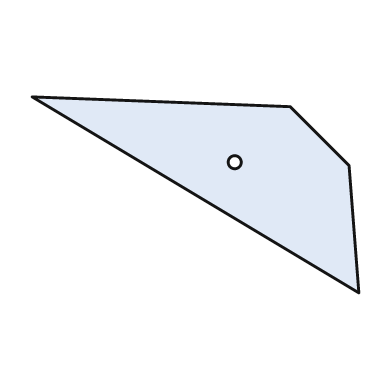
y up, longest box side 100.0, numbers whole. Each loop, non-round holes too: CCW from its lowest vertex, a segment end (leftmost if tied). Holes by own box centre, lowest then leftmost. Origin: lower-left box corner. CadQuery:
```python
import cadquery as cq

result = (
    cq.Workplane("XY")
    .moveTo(100.0, 0.0)
    .lineTo(97.0, 39.0)
    .lineTo(79.0, 57.0)
    .lineTo(0.0, 60.0)
    .close()
    .moveTo(62.0, 40.0)
    .circle(2.0)
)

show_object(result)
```